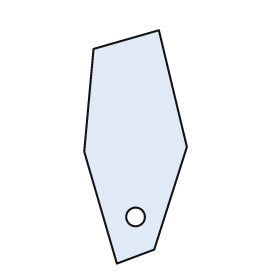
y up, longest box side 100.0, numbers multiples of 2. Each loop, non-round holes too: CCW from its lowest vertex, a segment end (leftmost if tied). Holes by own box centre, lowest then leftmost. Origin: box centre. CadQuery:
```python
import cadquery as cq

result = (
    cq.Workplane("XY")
    .moveTo(-8.0, -50.0)
    .lineTo(8.0, -44.0)
    .lineTo(22.0, 0.0)
    .lineTo(10.0, 50.0)
    .lineTo(-18.0, 42.0)
    .lineTo(-22.0, -2.0)
    .close()
    .moveTo(0.0, -30.0)
    .circle(4.0)
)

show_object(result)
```